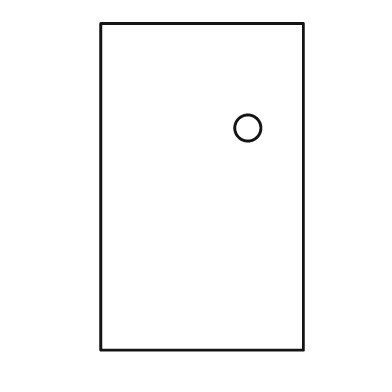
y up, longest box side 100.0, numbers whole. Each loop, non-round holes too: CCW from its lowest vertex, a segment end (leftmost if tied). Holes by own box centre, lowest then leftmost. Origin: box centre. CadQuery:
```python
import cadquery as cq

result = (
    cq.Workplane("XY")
    .moveTo(-31.0, -50.0)
    .lineTo(31.0, -50.0)
    .lineTo(31.0, 50.0)
    .lineTo(-31.0, 50.0)
    .close()
    .moveTo(14.0, 18.0)
    .circle(4.0)
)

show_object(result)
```